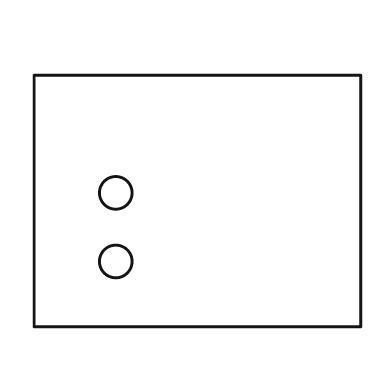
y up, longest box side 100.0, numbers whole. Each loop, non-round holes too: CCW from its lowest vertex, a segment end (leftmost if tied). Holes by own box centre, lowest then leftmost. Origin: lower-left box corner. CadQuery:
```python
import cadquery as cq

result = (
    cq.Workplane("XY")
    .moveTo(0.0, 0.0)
    .lineTo(100.0, 0.0)
    .lineTo(100.0, 77.0)
    .lineTo(0.0, 77.0)
    .close()
    .moveTo(25.0, 20.0)
    .circle(5.0)
    .moveTo(25.0, 41.0)
    .circle(5.0)
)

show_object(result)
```